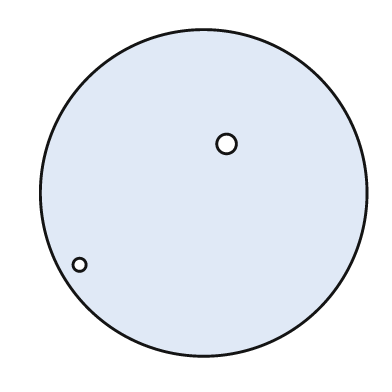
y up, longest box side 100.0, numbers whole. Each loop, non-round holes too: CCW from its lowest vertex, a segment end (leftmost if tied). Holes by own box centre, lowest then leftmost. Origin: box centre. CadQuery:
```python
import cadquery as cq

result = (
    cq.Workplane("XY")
    .moveTo(0.0, 0.0)
    .circle(50.0)
    .moveTo(-38.0, -22.0)
    .circle(2.0)
    .moveTo(7.0, 15.0)
    .circle(3.0)
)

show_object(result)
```